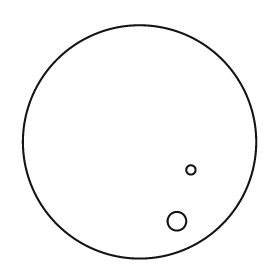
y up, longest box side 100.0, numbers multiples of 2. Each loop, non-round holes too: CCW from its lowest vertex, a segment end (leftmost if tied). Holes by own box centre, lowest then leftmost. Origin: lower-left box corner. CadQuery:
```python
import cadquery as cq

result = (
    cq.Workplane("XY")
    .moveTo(50.0, 50.0)
    .circle(50.0)
    .moveTo(66.0, 16.0)
    .circle(4.0)
    .moveTo(72.0, 38.0)
    .circle(2.0)
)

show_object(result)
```